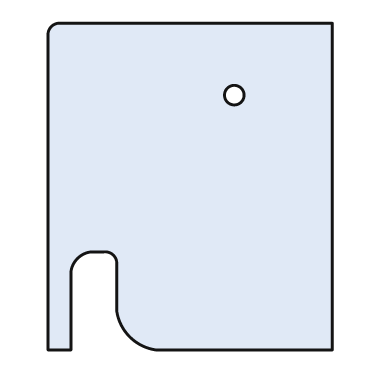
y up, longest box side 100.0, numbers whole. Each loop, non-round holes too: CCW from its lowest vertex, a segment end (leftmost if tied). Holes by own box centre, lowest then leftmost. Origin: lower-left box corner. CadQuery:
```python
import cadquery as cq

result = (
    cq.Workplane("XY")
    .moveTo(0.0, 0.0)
    .lineTo(7.0, 0.0)
    .lineTo(7.0, 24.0)
    .threePointArc((9.0, 28.0), (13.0, 30.0))
    .lineTo(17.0, 30.0)
    .threePointArc((20.0, 29.0), (21.0, 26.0))
    .lineTo(21.0, 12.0)
    .threePointArc((25.0, 4.0), (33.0, 0.0))
    .lineTo(87.0, 0.0)
    .lineTo(87.0, 100.0)
    .lineTo(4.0, 100.0)
    .threePointArc((1.0, 99.0), (0.0, 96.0))
    .close()
    .moveTo(57.0, 78.0)
    .circle(3.0)
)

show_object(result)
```